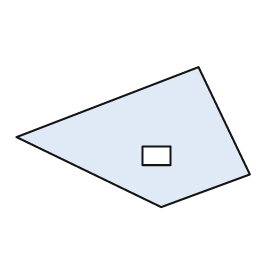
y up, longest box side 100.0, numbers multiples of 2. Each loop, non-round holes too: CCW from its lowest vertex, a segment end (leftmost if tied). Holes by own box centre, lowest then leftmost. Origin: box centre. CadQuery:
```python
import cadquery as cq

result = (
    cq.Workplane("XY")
    .moveTo(12.0, -30.0)
    .lineTo(50.0, -16.0)
    .lineTo(28.0, 30.0)
    .lineTo(-50.0, 0.0)
    .close()
    .moveTo(4.0, -12.0)
    .lineTo(16.0, -12.0)
    .lineTo(16.0, -4.0)
    .lineTo(4.0, -4.0)
    .close()
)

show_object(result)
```